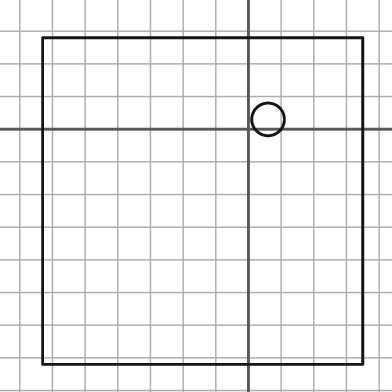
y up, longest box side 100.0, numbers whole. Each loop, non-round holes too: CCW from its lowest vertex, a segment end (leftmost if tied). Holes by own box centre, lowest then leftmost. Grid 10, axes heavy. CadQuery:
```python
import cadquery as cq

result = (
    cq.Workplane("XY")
    .moveTo(-63.0, -72.0)
    .lineTo(35.0, -72.0)
    .lineTo(35.0, 28.0)
    .lineTo(-63.0, 28.0)
    .close()
    .moveTo(6.0, 3.0)
    .circle(5.0)
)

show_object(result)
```